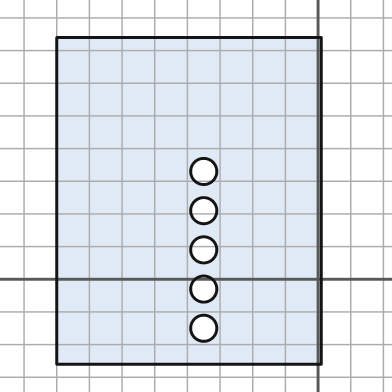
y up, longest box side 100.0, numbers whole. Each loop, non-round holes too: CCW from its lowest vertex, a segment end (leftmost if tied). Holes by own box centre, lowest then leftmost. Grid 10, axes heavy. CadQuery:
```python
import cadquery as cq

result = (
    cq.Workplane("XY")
    .moveTo(-80.0, -26.0)
    .lineTo(1.0, -26.0)
    .lineTo(1.0, 74.0)
    .lineTo(-80.0, 74.0)
    .close()
    .moveTo(-35.0, -15.0)
    .circle(4.0)
    .moveTo(-35.0, -3.0)
    .circle(4.0)
    .moveTo(-35.0, 9.0)
    .circle(4.0)
    .moveTo(-35.0, 21.0)
    .circle(4.0)
    .moveTo(-35.0, 33.0)
    .circle(4.0)
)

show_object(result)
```